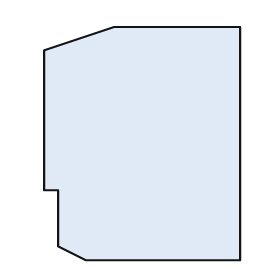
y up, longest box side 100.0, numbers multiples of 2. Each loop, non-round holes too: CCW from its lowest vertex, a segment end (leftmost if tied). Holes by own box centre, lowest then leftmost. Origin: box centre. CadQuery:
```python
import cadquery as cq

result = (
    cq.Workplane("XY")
    .moveTo(-24.0, -50.0)
    .lineTo(42.0, -50.0)
    .lineTo(42.0, 50.0)
    .lineTo(-12.0, 50.0)
    .lineTo(-42.0, 40.0)
    .lineTo(-42.0, -20.0)
    .lineTo(-36.0, -20.0)
    .lineTo(-36.0, -44.0)
    .close()
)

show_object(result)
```